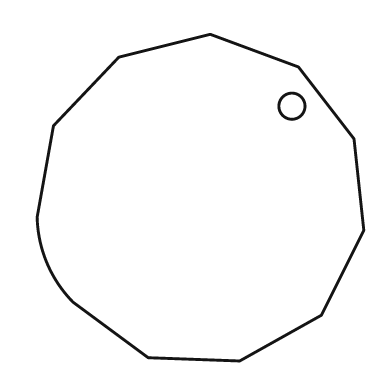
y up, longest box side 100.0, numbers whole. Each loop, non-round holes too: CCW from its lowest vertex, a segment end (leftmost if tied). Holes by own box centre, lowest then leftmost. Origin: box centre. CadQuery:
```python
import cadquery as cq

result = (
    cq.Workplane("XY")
    .moveTo(12.0, -50.0)
    .lineTo(37.0, -36.0)
    .lineTo(50.0, -10.0)
    .lineTo(47.0, 18.0)
    .lineTo(30.0, 40.0)
    .lineTo(3.0, 50.0)
    .lineTo(-25.0, 43.0)
    .lineTo(-45.0, 22.0)
    .lineTo(-50.0, -6.0)
    .threePointArc((-47.0, -20.0), (-39.0, -32.0))
    .lineTo(-16.0, -49.0)
    .close()
    .moveTo(28.0, 28.0)
    .circle(4.0)
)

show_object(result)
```